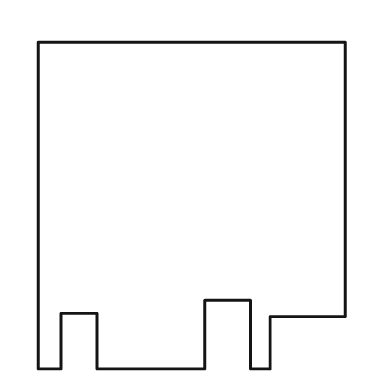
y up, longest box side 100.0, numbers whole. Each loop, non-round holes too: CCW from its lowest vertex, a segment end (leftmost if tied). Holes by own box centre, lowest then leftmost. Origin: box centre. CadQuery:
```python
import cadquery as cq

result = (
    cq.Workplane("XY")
    .moveTo(-47.0, -50.0)
    .lineTo(-40.0, -50.0)
    .lineTo(-40.0, -33.0)
    .lineTo(-29.0, -33.0)
    .lineTo(-29.0, -50.0)
    .lineTo(4.0, -50.0)
    .lineTo(4.0, -29.0)
    .lineTo(18.0, -29.0)
    .lineTo(18.0, -50.0)
    .lineTo(24.0, -50.0)
    .lineTo(24.0, -34.0)
    .lineTo(47.0, -34.0)
    .lineTo(47.0, 50.0)
    .lineTo(-47.0, 50.0)
    .close()
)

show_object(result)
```